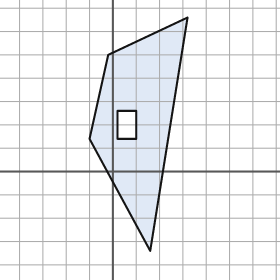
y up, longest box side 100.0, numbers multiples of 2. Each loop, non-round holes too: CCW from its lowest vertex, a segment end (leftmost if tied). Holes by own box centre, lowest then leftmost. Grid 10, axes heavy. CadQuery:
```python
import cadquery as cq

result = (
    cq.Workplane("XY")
    .moveTo(16.0, -34.0)
    .lineTo(32.0, 66.0)
    .lineTo(-2.0, 50.0)
    .lineTo(-10.0, 14.0)
    .close()
    .moveTo(2.0, 14.0)
    .lineTo(10.0, 14.0)
    .lineTo(10.0, 26.0)
    .lineTo(2.0, 26.0)
    .close()
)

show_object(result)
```